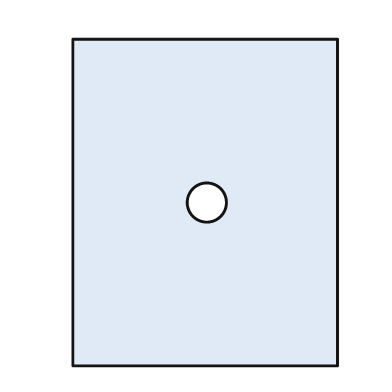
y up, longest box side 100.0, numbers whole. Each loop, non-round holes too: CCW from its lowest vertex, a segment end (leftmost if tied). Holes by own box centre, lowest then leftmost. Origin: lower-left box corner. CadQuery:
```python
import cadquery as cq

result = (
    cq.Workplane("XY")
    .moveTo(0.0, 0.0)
    .lineTo(81.0, 0.0)
    .lineTo(81.0, 100.0)
    .lineTo(0.0, 100.0)
    .close()
    .moveTo(41.0, 50.0)
    .circle(6.0)
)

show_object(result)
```